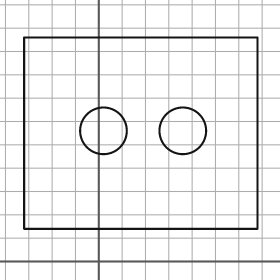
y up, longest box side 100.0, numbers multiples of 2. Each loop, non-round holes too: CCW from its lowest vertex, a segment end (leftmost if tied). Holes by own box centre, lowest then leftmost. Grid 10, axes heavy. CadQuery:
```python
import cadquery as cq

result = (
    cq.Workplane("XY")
    .moveTo(-32.0, 14.0)
    .lineTo(68.0, 14.0)
    .lineTo(68.0, 96.0)
    .lineTo(-32.0, 96.0)
    .close()
    .moveTo(2.0, 56.0)
    .circle(10.0)
    .moveTo(36.0, 56.0)
    .circle(10.0)
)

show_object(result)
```